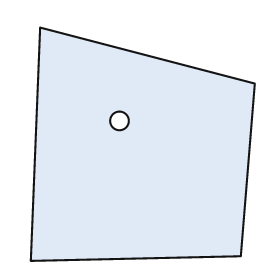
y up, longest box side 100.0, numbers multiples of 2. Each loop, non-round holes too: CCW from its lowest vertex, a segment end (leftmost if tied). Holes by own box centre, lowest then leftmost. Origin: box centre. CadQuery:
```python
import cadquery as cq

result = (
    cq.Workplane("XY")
    .moveTo(-48.0, -50.0)
    .lineTo(42.0, -48.0)
    .lineTo(48.0, 26.0)
    .lineTo(-44.0, 50.0)
    .close()
    .moveTo(-10.0, 10.0)
    .circle(4.0)
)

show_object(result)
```